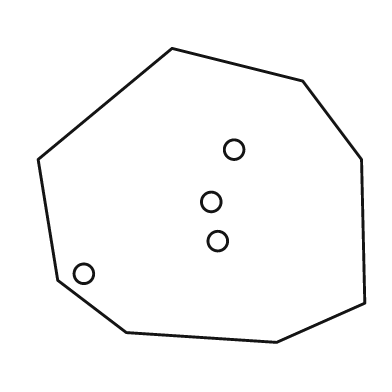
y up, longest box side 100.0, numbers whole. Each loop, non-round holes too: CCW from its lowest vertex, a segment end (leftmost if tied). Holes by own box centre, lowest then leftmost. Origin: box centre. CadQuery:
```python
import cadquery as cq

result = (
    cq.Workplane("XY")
    .moveTo(23.0, -45.0)
    .lineTo(50.0, -33.0)
    .lineTo(49.0, 11.0)
    .lineTo(31.0, 35.0)
    .lineTo(-9.0, 45.0)
    .lineTo(-50.0, 11.0)
    .lineTo(-44.0, -26.0)
    .lineTo(-23.0, -42.0)
    .close()
    .moveTo(-36.0, -24.0)
    .circle(3.0)
    .moveTo(5.0, -14.0)
    .circle(3.0)
    .moveTo(3.0, -2.0)
    .circle(3.0)
    .moveTo(10.0, 14.0)
    .circle(3.0)
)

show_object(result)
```